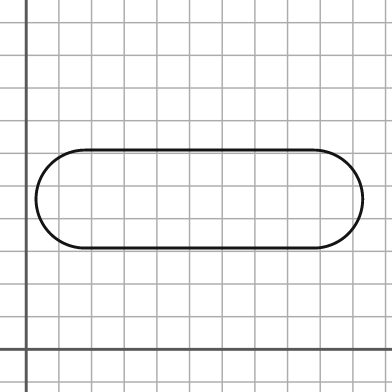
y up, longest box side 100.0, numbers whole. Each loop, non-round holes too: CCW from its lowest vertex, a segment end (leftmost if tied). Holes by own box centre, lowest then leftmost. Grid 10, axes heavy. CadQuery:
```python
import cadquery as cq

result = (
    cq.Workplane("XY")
    .moveTo(18.0, 31.0)
    .lineTo(88.0, 31.0)
    .threePointArc((103.0, 46.0), (88.0, 61.0))
    .lineTo(18.0, 61.0)
    .threePointArc((3.0, 46.0), (18.0, 31.0))
    .close()
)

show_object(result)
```